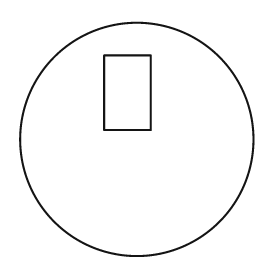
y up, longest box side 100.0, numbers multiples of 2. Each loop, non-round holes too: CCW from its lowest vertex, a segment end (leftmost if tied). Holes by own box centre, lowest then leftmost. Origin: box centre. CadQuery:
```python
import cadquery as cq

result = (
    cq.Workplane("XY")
    .moveTo(0.0, 0.0)
    .circle(50.0)
    .moveTo(-14.0, 4.0)
    .lineTo(6.0, 4.0)
    .lineTo(6.0, 36.0)
    .lineTo(-14.0, 36.0)
    .close()
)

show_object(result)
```